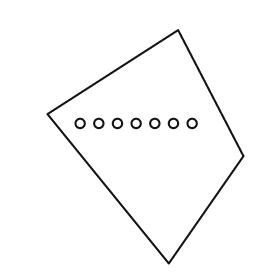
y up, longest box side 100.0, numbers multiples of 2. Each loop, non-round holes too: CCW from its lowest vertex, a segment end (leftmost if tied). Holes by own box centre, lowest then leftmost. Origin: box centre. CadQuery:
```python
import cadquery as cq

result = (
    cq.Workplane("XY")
    .moveTo(10.0, -50.0)
    .lineTo(42.0, -4.0)
    .lineTo(14.0, 50.0)
    .lineTo(-42.0, 14.0)
    .close()
    .moveTo(-28.0, 10.0)
    .circle(2.0)
    .moveTo(-20.0, 10.0)
    .circle(2.0)
    .moveTo(-12.0, 10.0)
    .circle(2.0)
    .moveTo(-4.0, 10.0)
    .circle(2.0)
    .moveTo(4.0, 10.0)
    .circle(2.0)
    .moveTo(12.0, 10.0)
    .circle(2.0)
    .moveTo(20.0, 10.0)
    .circle(2.0)
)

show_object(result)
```